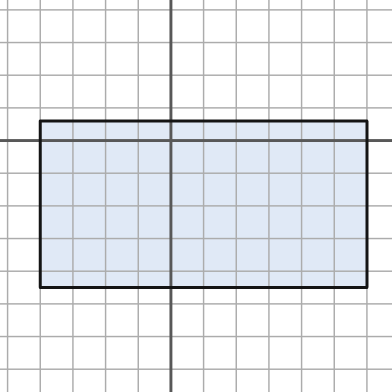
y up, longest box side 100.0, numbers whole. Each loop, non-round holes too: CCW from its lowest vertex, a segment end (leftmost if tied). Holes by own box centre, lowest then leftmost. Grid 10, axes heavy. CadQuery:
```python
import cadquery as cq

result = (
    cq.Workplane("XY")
    .moveTo(-40.0, -45.0)
    .lineTo(60.0, -45.0)
    .lineTo(60.0, 6.0)
    .lineTo(-40.0, 6.0)
    .close()
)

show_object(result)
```